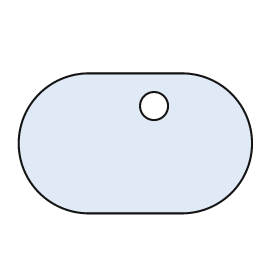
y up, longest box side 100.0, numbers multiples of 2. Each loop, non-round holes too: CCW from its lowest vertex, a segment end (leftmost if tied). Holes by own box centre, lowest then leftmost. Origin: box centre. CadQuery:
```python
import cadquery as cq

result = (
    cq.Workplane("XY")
    .moveTo(-20.0, -30.0)
    .lineTo(20.0, -30.0)
    .threePointArc((50.0, 0.0), (20.0, 30.0))
    .lineTo(-20.0, 30.0)
    .threePointArc((-50.0, 0.0), (-20.0, -30.0))
    .close()
    .moveTo(8.0, 16.0)
    .circle(6.0)
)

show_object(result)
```